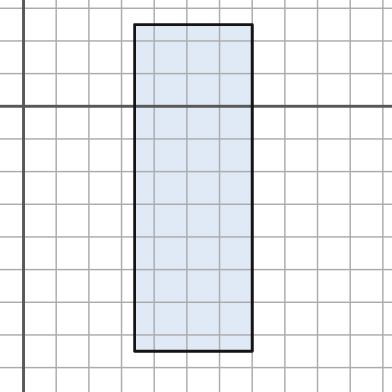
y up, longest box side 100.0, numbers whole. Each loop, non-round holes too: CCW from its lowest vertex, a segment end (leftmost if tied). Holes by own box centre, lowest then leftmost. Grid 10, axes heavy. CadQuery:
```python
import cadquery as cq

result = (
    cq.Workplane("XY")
    .moveTo(34.0, -75.0)
    .lineTo(70.0, -75.0)
    .lineTo(70.0, 25.0)
    .lineTo(34.0, 25.0)
    .close()
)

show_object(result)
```